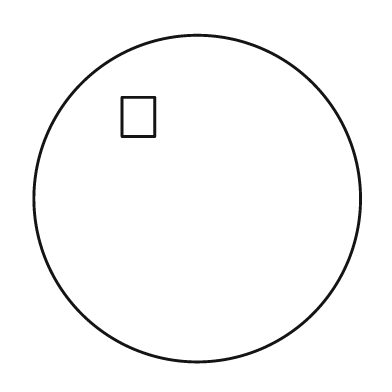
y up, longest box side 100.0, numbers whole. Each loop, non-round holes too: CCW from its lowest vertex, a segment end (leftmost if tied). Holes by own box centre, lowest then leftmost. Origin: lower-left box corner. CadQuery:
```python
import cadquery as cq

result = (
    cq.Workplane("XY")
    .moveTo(50.0, 50.0)
    .circle(50.0)
    .moveTo(27.0, 69.0)
    .lineTo(37.0, 69.0)
    .lineTo(37.0, 81.0)
    .lineTo(27.0, 81.0)
    .close()
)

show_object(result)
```